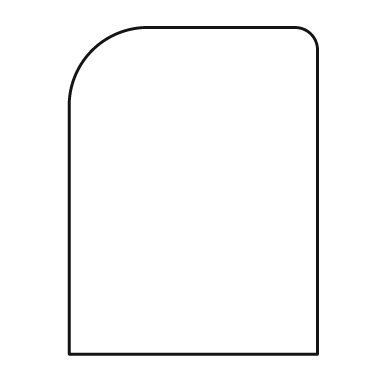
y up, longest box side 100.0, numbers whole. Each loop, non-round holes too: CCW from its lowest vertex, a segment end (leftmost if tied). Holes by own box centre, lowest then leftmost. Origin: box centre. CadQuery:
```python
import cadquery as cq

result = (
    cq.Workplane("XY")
    .moveTo(-38.0, -50.0)
    .lineTo(38.0, -50.0)
    .lineTo(38.0, 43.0)
    .threePointArc((36.0, 48.0), (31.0, 50.0))
    .lineTo(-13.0, 50.0)
    .threePointArc((-31.0, 43.0), (-38.0, 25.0))
    .close()
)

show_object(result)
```